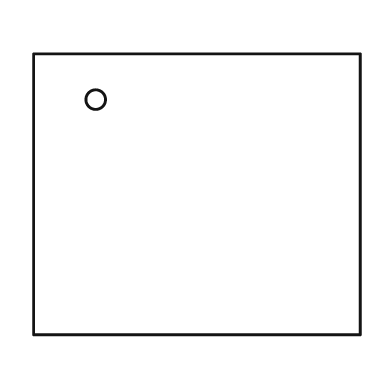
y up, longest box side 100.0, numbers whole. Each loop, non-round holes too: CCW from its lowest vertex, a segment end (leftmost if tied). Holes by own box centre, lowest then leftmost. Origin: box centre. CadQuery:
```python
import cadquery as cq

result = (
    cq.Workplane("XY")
    .moveTo(-50.0, -43.0)
    .lineTo(50.0, -43.0)
    .lineTo(50.0, 43.0)
    .lineTo(-50.0, 43.0)
    .close()
    .moveTo(-31.0, 29.0)
    .circle(3.0)
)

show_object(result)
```